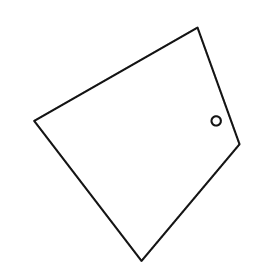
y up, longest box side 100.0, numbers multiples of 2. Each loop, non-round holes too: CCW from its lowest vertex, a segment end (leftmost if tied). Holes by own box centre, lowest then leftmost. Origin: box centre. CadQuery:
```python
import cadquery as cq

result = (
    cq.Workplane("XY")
    .moveTo(2.0, -50.0)
    .lineTo(44.0, 0.0)
    .lineTo(26.0, 50.0)
    .lineTo(-44.0, 10.0)
    .close()
    .moveTo(34.0, 10.0)
    .circle(2.0)
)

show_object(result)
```